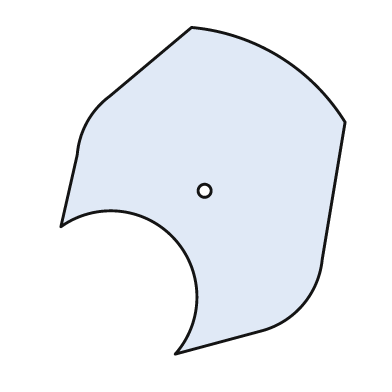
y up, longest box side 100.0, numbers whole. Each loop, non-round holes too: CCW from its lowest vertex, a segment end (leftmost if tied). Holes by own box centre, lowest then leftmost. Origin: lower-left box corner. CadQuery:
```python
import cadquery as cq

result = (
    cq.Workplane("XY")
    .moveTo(35.0, 0.0)
    .lineTo(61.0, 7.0)
    .threePointArc((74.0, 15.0), (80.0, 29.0))
    .lineTo(87.0, 71.0)
    .threePointArc((67.0, 91.0), (40.0, 100.0))
    .lineTo(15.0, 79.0)
    .threePointArc((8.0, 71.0), (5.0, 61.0))
    .lineTo(0.0, 39.0)
    .threePointArc((35.0, 35.0), (35.0, 0.0))
    .close()
    .moveTo(44.0, 50.0)
    .circle(2.0)
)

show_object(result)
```